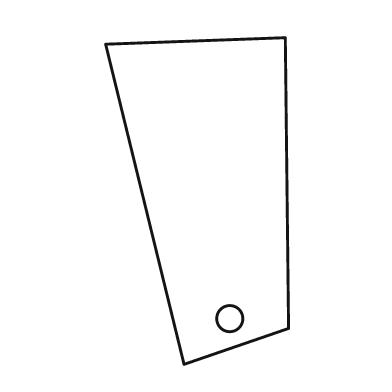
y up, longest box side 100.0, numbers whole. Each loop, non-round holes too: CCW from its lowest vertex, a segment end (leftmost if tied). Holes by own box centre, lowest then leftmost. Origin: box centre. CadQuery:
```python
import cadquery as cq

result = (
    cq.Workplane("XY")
    .moveTo(-4.0, -50.0)
    .lineTo(28.0, -39.0)
    .lineTo(27.0, 50.0)
    .lineTo(-28.0, 48.0)
    .close()
    .moveTo(10.0, -36.0)
    .circle(4.0)
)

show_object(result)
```